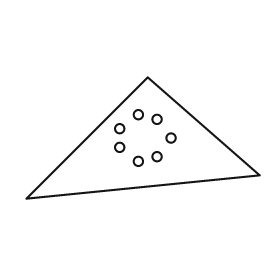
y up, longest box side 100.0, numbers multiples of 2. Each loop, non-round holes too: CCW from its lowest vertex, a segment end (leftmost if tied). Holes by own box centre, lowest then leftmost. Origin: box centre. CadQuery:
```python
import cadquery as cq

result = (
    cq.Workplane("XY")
    .moveTo(-50.0, -26.0)
    .lineTo(50.0, -16.0)
    .lineTo(2.0, 26.0)
    .close()
    .moveTo(-2.0, -10.0)
    .circle(2.0)
    .moveTo(6.0, -8.0)
    .circle(2.0)
    .moveTo(-10.0, -4.0)
    .circle(2.0)
    .moveTo(12.0, 0.0)
    .circle(2.0)
    .moveTo(-10.0, 4.0)
    .circle(2.0)
    .moveTo(6.0, 8.0)
    .circle(2.0)
    .moveTo(-2.0, 10.0)
    .circle(2.0)
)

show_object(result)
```